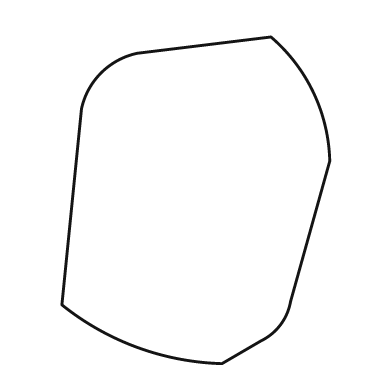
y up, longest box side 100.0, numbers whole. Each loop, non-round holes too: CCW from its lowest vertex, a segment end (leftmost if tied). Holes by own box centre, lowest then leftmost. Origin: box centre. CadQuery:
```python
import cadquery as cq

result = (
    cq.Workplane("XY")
    .moveTo(8.0, -50.0)
    .lineTo(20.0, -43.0)
    .threePointArc((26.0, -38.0), (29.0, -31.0))
    .lineTo(41.0, 12.0)
    .threePointArc((36.0, 33.0), (23.0, 50.0))
    .lineTo(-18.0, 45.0)
    .threePointArc((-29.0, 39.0), (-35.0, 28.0))
    .lineTo(-41.0, -32.0)
    .threePointArc((-18.0, -45.0), (8.0, -50.0))
    .close()
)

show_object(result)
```